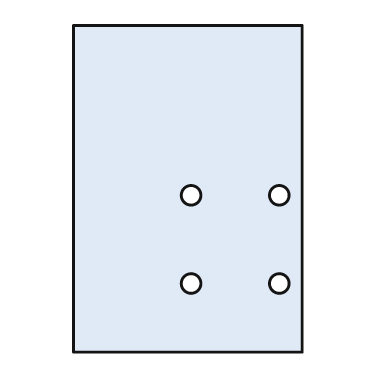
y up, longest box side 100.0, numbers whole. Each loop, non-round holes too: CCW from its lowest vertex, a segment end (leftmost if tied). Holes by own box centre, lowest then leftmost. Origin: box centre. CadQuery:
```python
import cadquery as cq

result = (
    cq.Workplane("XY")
    .moveTo(-35.0, -50.0)
    .lineTo(35.0, -50.0)
    .lineTo(35.0, 50.0)
    .lineTo(-35.0, 50.0)
    .close()
    .moveTo(1.0, -29.0)
    .circle(3.0)
    .moveTo(28.0, -29.0)
    .circle(3.0)
    .moveTo(1.0, -2.0)
    .circle(3.0)
    .moveTo(28.0, -2.0)
    .circle(3.0)
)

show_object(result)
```